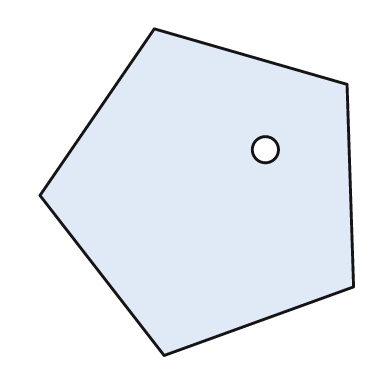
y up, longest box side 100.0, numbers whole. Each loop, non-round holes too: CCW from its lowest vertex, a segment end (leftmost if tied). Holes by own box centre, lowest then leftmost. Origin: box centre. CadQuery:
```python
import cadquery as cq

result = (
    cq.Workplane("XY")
    .moveTo(-10.0, -50.0)
    .lineTo(48.0, -29.0)
    .lineTo(46.0, 33.0)
    .lineTo(-13.0, 50.0)
    .lineTo(-48.0, -1.0)
    .close()
    .moveTo(21.0, 13.0)
    .circle(4.0)
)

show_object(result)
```